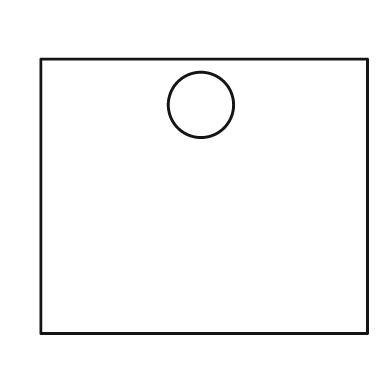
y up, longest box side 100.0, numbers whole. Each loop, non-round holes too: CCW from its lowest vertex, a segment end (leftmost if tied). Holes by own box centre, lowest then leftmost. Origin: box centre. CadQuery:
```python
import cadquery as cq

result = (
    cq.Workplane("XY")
    .moveTo(-50.0, -42.0)
    .lineTo(50.0, -42.0)
    .lineTo(50.0, 42.0)
    .lineTo(-50.0, 42.0)
    .close()
    .moveTo(-1.0, 28.0)
    .circle(10.0)
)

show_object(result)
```